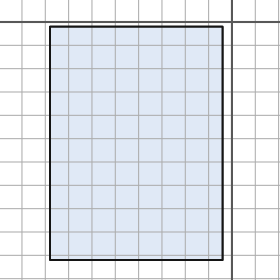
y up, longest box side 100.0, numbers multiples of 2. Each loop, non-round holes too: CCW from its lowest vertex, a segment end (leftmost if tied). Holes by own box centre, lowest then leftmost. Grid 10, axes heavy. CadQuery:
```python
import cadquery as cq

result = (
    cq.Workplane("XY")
    .moveTo(-78.0, -102.0)
    .lineTo(-4.0, -102.0)
    .lineTo(-4.0, -2.0)
    .lineTo(-78.0, -2.0)
    .close()
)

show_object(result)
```